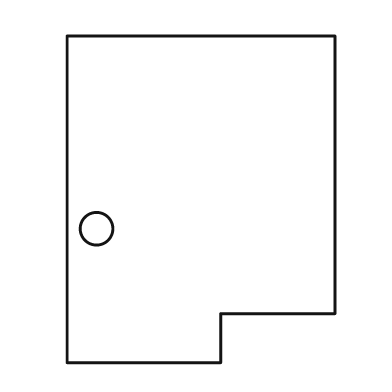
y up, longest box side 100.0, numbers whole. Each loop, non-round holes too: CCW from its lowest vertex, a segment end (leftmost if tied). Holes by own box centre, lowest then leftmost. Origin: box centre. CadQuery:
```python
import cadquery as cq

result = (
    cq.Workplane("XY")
    .moveTo(-41.0, -50.0)
    .lineTo(6.0, -50.0)
    .lineTo(6.0, -35.0)
    .lineTo(41.0, -35.0)
    .lineTo(41.0, 50.0)
    .lineTo(-41.0, 50.0)
    .close()
    .moveTo(-32.0, -9.0)
    .circle(5.0)
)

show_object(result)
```